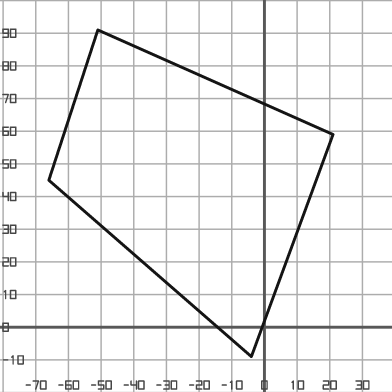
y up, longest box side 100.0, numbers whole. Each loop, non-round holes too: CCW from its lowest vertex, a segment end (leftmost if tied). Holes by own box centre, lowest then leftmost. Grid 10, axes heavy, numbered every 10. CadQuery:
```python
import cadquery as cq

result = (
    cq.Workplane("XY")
    .moveTo(-4.0, -9.0)
    .lineTo(21.0, 59.0)
    .lineTo(-51.0, 91.0)
    .lineTo(-66.0, 45.0)
    .close()
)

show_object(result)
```